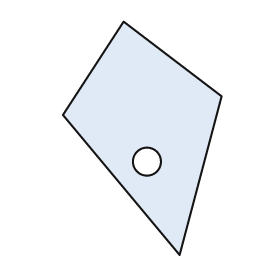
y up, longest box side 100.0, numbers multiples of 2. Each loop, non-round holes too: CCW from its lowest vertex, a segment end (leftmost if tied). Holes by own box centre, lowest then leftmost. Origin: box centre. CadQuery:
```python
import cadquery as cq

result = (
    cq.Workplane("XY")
    .moveTo(16.0, -50.0)
    .lineTo(34.0, 18.0)
    .lineTo(-8.0, 50.0)
    .lineTo(-34.0, 10.0)
    .close()
    .moveTo(2.0, -10.0)
    .circle(6.0)
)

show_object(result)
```